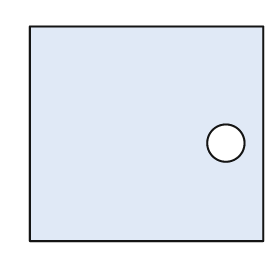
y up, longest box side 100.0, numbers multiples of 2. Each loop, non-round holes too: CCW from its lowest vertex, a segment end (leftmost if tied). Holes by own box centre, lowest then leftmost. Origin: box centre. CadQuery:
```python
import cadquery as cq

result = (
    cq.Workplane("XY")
    .moveTo(-50.0, -46.0)
    .lineTo(50.0, -46.0)
    .lineTo(50.0, 46.0)
    .lineTo(-50.0, 46.0)
    .close()
    .moveTo(34.0, -4.0)
    .circle(8.0)
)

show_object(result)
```